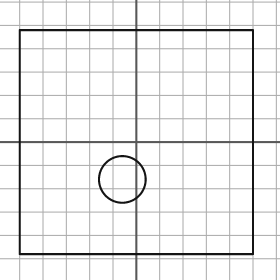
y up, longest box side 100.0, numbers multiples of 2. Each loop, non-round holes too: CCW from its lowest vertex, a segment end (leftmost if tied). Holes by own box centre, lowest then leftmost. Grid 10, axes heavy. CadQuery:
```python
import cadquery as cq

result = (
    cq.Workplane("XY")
    .moveTo(-50.0, -48.0)
    .lineTo(50.0, -48.0)
    .lineTo(50.0, 48.0)
    .lineTo(-50.0, 48.0)
    .close()
    .moveTo(-6.0, -16.0)
    .circle(10.0)
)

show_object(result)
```